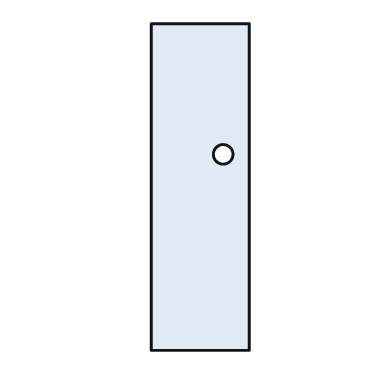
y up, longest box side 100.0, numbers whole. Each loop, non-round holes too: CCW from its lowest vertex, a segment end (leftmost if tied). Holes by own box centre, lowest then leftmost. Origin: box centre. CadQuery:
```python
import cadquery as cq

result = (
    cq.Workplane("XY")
    .moveTo(-15.0, -50.0)
    .lineTo(15.0, -50.0)
    .lineTo(15.0, 50.0)
    .lineTo(-15.0, 50.0)
    .close()
    .moveTo(7.0, 10.0)
    .circle(3.0)
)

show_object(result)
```